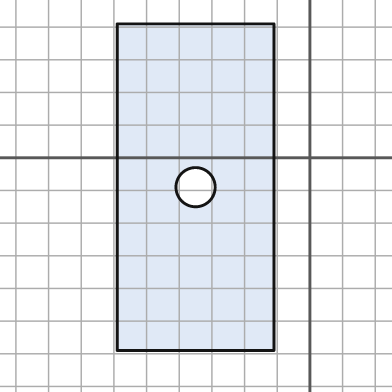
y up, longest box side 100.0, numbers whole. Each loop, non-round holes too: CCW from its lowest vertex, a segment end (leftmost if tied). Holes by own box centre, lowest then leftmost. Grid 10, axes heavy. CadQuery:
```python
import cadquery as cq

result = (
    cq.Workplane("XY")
    .moveTo(-59.0, -59.0)
    .lineTo(-11.0, -59.0)
    .lineTo(-11.0, 41.0)
    .lineTo(-59.0, 41.0)
    .close()
    .moveTo(-35.0, -9.0)
    .circle(6.0)
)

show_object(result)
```